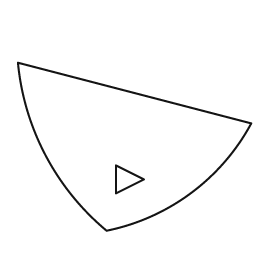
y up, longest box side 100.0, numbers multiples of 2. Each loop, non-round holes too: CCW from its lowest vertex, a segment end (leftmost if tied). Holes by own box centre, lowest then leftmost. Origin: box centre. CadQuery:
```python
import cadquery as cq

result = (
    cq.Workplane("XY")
    .moveTo(-12.0, -36.0)
    .threePointArc((24.0, -20.0), (50.0, 10.0))
    .lineTo(-50.0, 36.0)
    .threePointArc((-38.0, -4.0), (-12.0, -36.0))
    .close()
    .moveTo(-8.0, -20.0)
    .lineTo(4.0, -14.0)
    .lineTo(-8.0, -8.0)
    .close()
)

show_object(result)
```